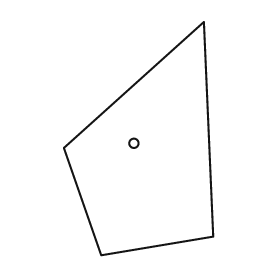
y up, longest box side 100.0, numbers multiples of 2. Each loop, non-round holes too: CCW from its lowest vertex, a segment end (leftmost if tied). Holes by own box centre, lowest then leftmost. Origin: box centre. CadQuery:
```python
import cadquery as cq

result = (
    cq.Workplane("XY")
    .moveTo(-16.0, -50.0)
    .lineTo(32.0, -42.0)
    .lineTo(28.0, 50.0)
    .lineTo(-32.0, -4.0)
    .close()
    .moveTo(-2.0, -2.0)
    .circle(2.0)
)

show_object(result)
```